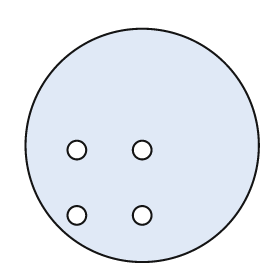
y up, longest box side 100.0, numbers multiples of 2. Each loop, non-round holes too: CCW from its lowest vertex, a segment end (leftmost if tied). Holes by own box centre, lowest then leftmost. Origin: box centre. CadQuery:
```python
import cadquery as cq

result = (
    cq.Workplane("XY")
    .moveTo(0.0, 0.0)
    .circle(50.0)
    .moveTo(-28.0, -30.0)
    .circle(4.0)
    .moveTo(0.0, -30.0)
    .circle(4.0)
    .moveTo(-28.0, -2.0)
    .circle(4.0)
    .moveTo(0.0, -2.0)
    .circle(4.0)
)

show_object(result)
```